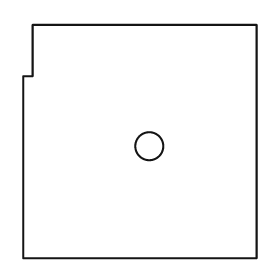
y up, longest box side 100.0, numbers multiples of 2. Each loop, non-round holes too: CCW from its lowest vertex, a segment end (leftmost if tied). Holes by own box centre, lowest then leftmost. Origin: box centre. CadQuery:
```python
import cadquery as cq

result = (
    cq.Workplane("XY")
    .moveTo(-50.0, -50.0)
    .lineTo(50.0, -50.0)
    .lineTo(50.0, 50.0)
    .lineTo(-46.0, 50.0)
    .lineTo(-46.0, 28.0)
    .lineTo(-50.0, 28.0)
    .close()
    .moveTo(4.0, -2.0)
    .circle(6.0)
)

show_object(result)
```